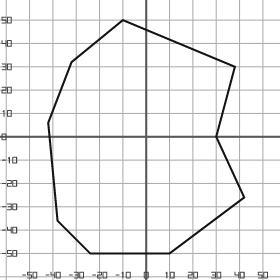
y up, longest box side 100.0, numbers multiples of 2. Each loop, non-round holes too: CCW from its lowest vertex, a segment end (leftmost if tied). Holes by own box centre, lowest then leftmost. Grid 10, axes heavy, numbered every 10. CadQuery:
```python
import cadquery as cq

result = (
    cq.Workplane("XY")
    .moveTo(-24.0, -50.0)
    .lineTo(10.0, -50.0)
    .lineTo(42.0, -26.0)
    .lineTo(30.0, 0.0)
    .lineTo(38.0, 30.0)
    .lineTo(-10.0, 50.0)
    .lineTo(-32.0, 32.0)
    .lineTo(-42.0, 6.0)
    .lineTo(-38.0, -36.0)
    .close()
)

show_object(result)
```